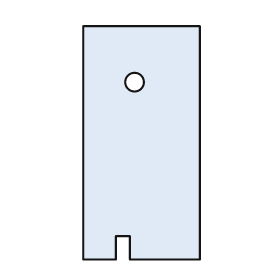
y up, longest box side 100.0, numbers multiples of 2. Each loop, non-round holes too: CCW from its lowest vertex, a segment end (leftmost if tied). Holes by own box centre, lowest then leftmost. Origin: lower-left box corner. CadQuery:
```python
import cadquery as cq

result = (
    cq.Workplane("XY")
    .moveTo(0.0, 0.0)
    .lineTo(14.0, 0.0)
    .lineTo(14.0, 10.0)
    .lineTo(20.0, 10.0)
    .lineTo(20.0, 0.0)
    .lineTo(50.0, 0.0)
    .lineTo(50.0, 100.0)
    .lineTo(0.0, 100.0)
    .close()
    .moveTo(22.0, 76.0)
    .circle(4.0)
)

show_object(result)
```